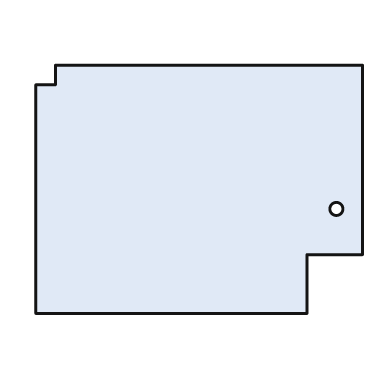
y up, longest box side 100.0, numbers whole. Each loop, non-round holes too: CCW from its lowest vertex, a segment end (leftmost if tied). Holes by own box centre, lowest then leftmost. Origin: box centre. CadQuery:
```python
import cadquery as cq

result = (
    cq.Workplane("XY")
    .moveTo(-50.0, -38.0)
    .lineTo(33.0, -38.0)
    .lineTo(33.0, -20.0)
    .lineTo(50.0, -20.0)
    .lineTo(50.0, 38.0)
    .lineTo(-44.0, 38.0)
    .lineTo(-44.0, 32.0)
    .lineTo(-50.0, 32.0)
    .close()
    .moveTo(42.0, -6.0)
    .circle(2.0)
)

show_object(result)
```